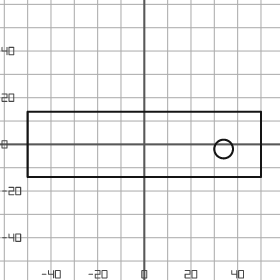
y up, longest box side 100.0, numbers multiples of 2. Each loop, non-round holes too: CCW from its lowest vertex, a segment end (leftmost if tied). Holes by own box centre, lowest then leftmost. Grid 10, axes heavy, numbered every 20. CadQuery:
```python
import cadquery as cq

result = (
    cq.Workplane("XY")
    .moveTo(-50.0, -14.0)
    .lineTo(50.0, -14.0)
    .lineTo(50.0, 14.0)
    .lineTo(-50.0, 14.0)
    .close()
    .moveTo(34.0, -2.0)
    .circle(4.0)
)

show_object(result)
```